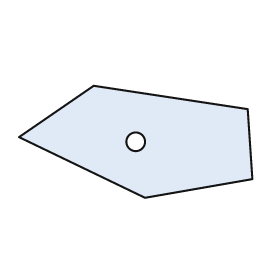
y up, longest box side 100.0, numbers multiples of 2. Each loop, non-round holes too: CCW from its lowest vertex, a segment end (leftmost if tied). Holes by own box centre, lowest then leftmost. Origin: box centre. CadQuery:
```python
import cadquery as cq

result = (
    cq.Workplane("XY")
    .moveTo(4.0, -24.0)
    .lineTo(50.0, -16.0)
    .lineTo(48.0, 14.0)
    .lineTo(-18.0, 24.0)
    .lineTo(-50.0, 2.0)
    .close()
    .moveTo(0.0, 0.0)
    .circle(4.0)
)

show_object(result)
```